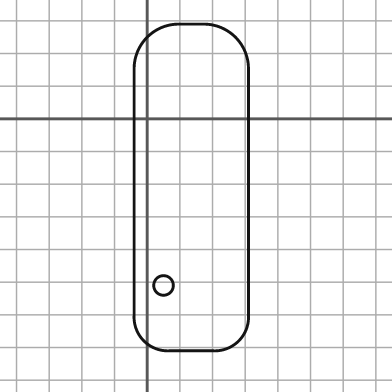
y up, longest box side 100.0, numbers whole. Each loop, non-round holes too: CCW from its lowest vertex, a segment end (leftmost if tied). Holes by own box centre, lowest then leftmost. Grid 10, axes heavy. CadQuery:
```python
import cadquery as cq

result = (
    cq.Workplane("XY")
    .moveTo(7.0, -71.0)
    .lineTo(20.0, -71.0)
    .threePointArc((28.0, -68.0), (31.0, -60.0))
    .lineTo(31.0, 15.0)
    .threePointArc((27.0, 25.0), (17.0, 29.0))
    .lineTo(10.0, 29.0)
    .threePointArc((0.0, 25.0), (-4.0, 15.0))
    .lineTo(-4.0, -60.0)
    .threePointArc((-1.0, -68.0), (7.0, -71.0))
    .close()
    .moveTo(5.0, -51.0)
    .circle(3.0)
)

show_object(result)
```